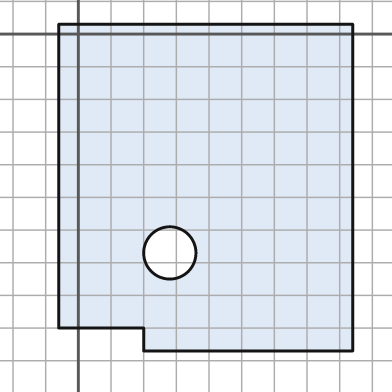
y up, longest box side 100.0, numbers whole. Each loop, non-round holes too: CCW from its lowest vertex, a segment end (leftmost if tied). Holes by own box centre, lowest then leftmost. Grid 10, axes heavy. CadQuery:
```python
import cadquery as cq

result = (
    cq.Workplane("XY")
    .moveTo(20.0, -97.0)
    .lineTo(84.0, -97.0)
    .lineTo(84.0, 3.0)
    .lineTo(-6.0, 3.0)
    .lineTo(-6.0, -90.0)
    .lineTo(20.0, -90.0)
    .close()
    .moveTo(28.0, -67.0)
    .circle(8.0)
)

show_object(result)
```